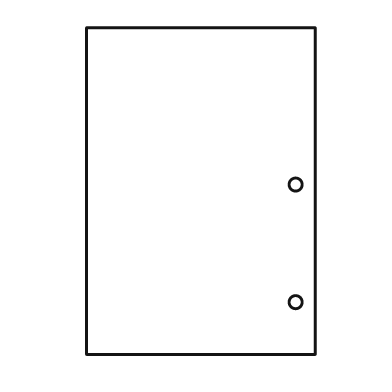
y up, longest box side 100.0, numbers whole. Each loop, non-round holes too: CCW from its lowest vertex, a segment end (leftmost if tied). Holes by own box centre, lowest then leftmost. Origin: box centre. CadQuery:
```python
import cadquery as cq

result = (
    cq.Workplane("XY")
    .moveTo(-35.0, -50.0)
    .lineTo(35.0, -50.0)
    .lineTo(35.0, 50.0)
    .lineTo(-35.0, 50.0)
    .close()
    .moveTo(29.0, -34.0)
    .circle(2.0)
    .moveTo(29.0, 2.0)
    .circle(2.0)
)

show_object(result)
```